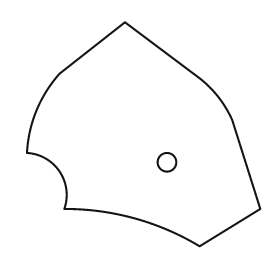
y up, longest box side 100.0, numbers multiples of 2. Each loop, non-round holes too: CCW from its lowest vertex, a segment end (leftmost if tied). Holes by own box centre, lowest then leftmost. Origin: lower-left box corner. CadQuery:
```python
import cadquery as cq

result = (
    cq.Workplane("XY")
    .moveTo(74.0, 0.0)
    .lineTo(100.0, 16.0)
    .lineTo(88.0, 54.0)
    .threePointArc((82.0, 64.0), (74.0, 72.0))
    .lineTo(42.0, 96.0)
    .lineTo(14.0, 74.0)
    .threePointArc((4.0, 58.0), (0.0, 40.0))
    .threePointArc((14.0, 32.0), (16.0, 16.0))
    .threePointArc((46.0, 12.0), (74.0, 0.0))
    .close()
    .moveTo(60.0, 36.0)
    .circle(4.0)
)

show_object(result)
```